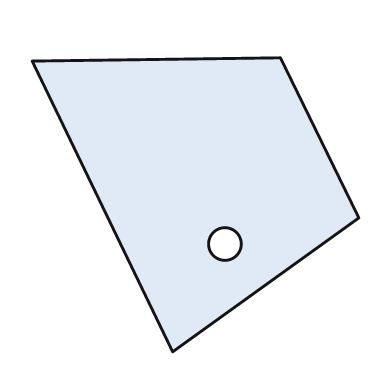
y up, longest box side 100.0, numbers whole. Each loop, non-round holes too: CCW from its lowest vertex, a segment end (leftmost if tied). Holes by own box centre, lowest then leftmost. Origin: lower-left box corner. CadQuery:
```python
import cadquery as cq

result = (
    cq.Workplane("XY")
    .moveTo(43.0, 0.0)
    .lineTo(100.0, 41.0)
    .lineTo(76.0, 90.0)
    .lineTo(0.0, 89.0)
    .close()
    .moveTo(59.0, 33.0)
    .circle(5.0)
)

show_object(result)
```